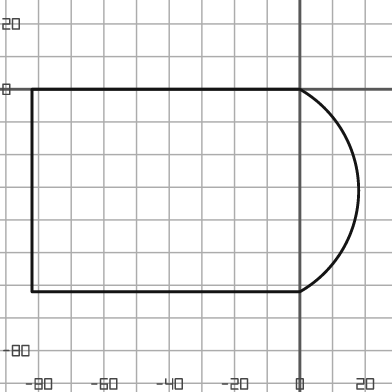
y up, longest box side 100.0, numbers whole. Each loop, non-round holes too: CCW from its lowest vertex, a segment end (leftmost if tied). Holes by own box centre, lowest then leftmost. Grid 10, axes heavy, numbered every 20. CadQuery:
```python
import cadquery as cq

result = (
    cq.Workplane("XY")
    .moveTo(-82.0, -62.0)
    .lineTo(0.0, -62.0)
    .threePointArc((18.0, -31.0), (0.0, 0.0))
    .lineTo(-82.0, 0.0)
    .close()
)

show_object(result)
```